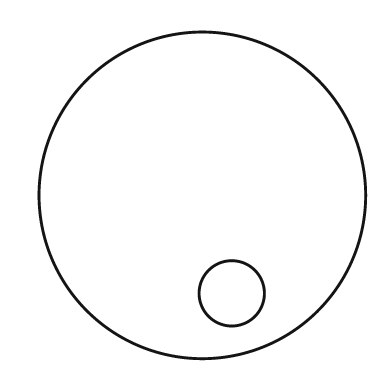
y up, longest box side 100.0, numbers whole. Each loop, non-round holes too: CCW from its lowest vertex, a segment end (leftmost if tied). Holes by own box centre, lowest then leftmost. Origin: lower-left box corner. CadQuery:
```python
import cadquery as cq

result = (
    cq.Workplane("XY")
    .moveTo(50.0, 50.0)
    .circle(50.0)
    .moveTo(59.0, 20.0)
    .circle(10.0)
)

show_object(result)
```